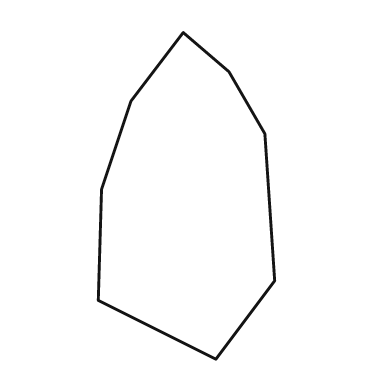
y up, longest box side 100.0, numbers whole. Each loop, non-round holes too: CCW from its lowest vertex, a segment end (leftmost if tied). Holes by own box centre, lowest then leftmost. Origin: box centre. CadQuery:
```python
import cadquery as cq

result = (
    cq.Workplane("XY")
    .moveTo(9.0, -50.0)
    .lineTo(27.0, -26.0)
    .lineTo(24.0, 19.0)
    .lineTo(13.0, 38.0)
    .lineTo(-1.0, 50.0)
    .lineTo(-17.0, 29.0)
    .lineTo(-26.0, 2.0)
    .lineTo(-27.0, -32.0)
    .close()
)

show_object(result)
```